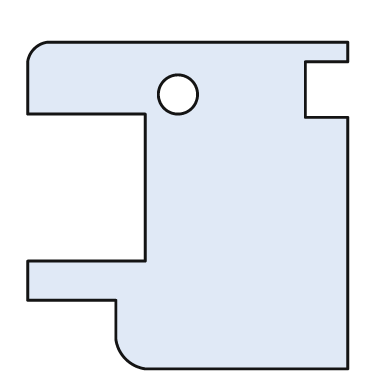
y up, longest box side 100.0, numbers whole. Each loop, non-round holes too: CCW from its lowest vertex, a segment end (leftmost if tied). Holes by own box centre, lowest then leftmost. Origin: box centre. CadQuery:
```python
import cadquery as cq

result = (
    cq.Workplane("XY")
    .moveTo(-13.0, -50.0)
    .lineTo(49.0, -50.0)
    .lineTo(49.0, 27.0)
    .lineTo(36.0, 27.0)
    .lineTo(36.0, 44.0)
    .lineTo(49.0, 44.0)
    .lineTo(49.0, 50.0)
    .lineTo(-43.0, 50.0)
    .threePointArc((-47.0, 48.0), (-49.0, 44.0))
    .lineTo(-49.0, 28.0)
    .lineTo(-13.0, 28.0)
    .lineTo(-13.0, -17.0)
    .lineTo(-49.0, -17.0)
    .lineTo(-49.0, -29.0)
    .lineTo(-22.0, -29.0)
    .lineTo(-22.0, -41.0)
    .threePointArc((-19.0, -47.0), (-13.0, -50.0))
    .close()
    .moveTo(-3.0, 34.0)
    .circle(6.0)
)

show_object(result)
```